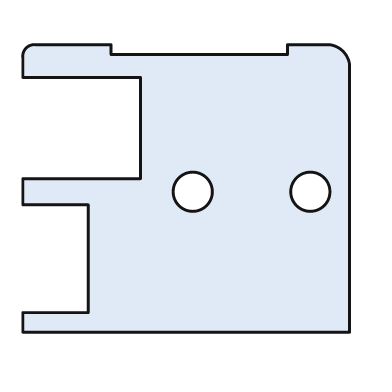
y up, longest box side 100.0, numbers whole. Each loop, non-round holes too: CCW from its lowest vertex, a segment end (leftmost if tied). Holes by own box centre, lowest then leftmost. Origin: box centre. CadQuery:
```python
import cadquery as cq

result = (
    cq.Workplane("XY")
    .moveTo(-50.0, -44.0)
    .lineTo(50.0, -44.0)
    .lineTo(50.0, 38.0)
    .threePointArc((48.0, 42.0), (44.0, 44.0))
    .lineTo(31.0, 44.0)
    .lineTo(31.0, 41.0)
    .lineTo(-23.0, 41.0)
    .lineTo(-23.0, 44.0)
    .lineTo(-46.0, 44.0)
    .threePointArc((-49.0, 43.0), (-50.0, 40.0))
    .lineTo(-50.0, 34.0)
    .lineTo(-14.0, 34.0)
    .lineTo(-14.0, 3.0)
    .lineTo(-50.0, 3.0)
    .lineTo(-50.0, -5.0)
    .lineTo(-30.0, -5.0)
    .lineTo(-30.0, -38.0)
    .lineTo(-50.0, -38.0)
    .close()
    .moveTo(2.0, -1.0)
    .circle(6.0)
    .moveTo(38.0, -1.0)
    .circle(6.0)
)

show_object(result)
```